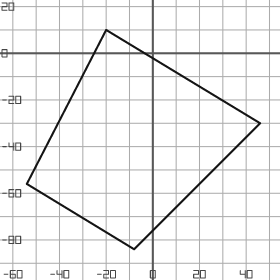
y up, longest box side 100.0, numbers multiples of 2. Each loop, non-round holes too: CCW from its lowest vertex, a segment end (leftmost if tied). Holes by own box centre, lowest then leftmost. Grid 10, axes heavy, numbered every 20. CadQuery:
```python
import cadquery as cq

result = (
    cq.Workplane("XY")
    .moveTo(-8.0, -84.0)
    .lineTo(46.0, -30.0)
    .lineTo(-20.0, 10.0)
    .lineTo(-54.0, -56.0)
    .close()
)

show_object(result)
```